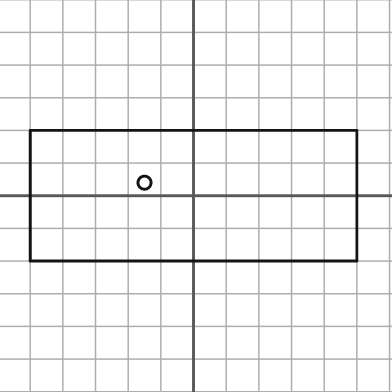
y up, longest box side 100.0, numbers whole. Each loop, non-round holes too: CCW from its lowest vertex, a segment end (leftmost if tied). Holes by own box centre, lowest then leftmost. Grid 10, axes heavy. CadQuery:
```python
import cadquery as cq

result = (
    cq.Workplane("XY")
    .moveTo(-50.0, -20.0)
    .lineTo(50.0, -20.0)
    .lineTo(50.0, 20.0)
    .lineTo(-50.0, 20.0)
    .close()
    .moveTo(-15.0, 4.0)
    .circle(2.0)
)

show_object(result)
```